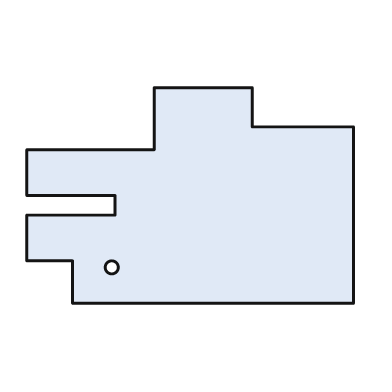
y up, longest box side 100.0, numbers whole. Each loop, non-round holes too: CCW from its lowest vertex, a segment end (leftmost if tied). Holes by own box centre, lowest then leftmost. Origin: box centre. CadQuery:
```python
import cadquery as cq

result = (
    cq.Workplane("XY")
    .moveTo(-36.0, -33.0)
    .lineTo(50.0, -33.0)
    .lineTo(50.0, 21.0)
    .lineTo(19.0, 21.0)
    .lineTo(19.0, 33.0)
    .lineTo(-11.0, 33.0)
    .lineTo(-11.0, 14.0)
    .lineTo(-50.0, 14.0)
    .lineTo(-50.0, 0.0)
    .lineTo(-23.0, 0.0)
    .lineTo(-23.0, -6.0)
    .lineTo(-50.0, -6.0)
    .lineTo(-50.0, -20.0)
    .lineTo(-36.0, -20.0)
    .close()
    .moveTo(-24.0, -22.0)
    .circle(2.0)
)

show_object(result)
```